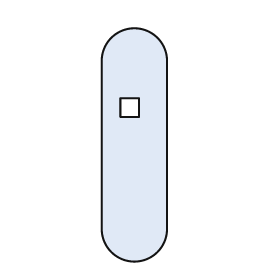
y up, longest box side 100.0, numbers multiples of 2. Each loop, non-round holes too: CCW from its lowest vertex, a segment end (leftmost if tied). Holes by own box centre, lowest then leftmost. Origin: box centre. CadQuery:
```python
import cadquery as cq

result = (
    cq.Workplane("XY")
    .moveTo(-14.0, -36.0)
    .threePointArc((0.0, -50.0), (14.0, -36.0))
    .lineTo(14.0, 36.0)
    .threePointArc((0.0, 50.0), (-14.0, 36.0))
    .close()
    .moveTo(-6.0, 12.0)
    .lineTo(2.0, 12.0)
    .lineTo(2.0, 20.0)
    .lineTo(-6.0, 20.0)
    .close()
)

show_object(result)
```